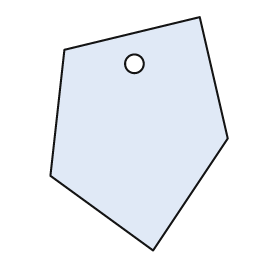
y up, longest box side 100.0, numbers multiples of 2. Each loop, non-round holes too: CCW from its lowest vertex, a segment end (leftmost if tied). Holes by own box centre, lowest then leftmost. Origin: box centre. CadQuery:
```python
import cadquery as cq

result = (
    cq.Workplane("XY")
    .moveTo(6.0, -50.0)
    .lineTo(38.0, -2.0)
    .lineTo(26.0, 50.0)
    .lineTo(-32.0, 36.0)
    .lineTo(-38.0, -18.0)
    .close()
    .moveTo(-2.0, 30.0)
    .circle(4.0)
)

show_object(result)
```